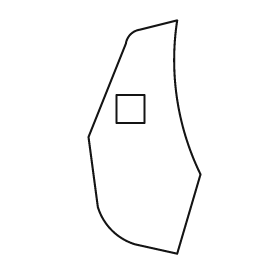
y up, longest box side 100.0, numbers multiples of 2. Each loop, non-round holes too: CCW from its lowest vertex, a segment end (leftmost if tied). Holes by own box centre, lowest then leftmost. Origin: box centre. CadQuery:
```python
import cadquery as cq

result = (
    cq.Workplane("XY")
    .moveTo(14.0, -50.0)
    .lineTo(24.0, -16.0)
    .threePointArc((14.0, 16.0), (14.0, 50.0))
    .lineTo(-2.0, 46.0)
    .threePointArc((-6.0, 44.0), (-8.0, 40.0))
    .lineTo(-24.0, 0.0)
    .lineTo(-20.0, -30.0)
    .threePointArc((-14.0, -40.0), (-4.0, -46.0))
    .close()
    .moveTo(-12.0, 6.0)
    .lineTo(0.0, 6.0)
    .lineTo(0.0, 18.0)
    .lineTo(-12.0, 18.0)
    .close()
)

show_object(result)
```